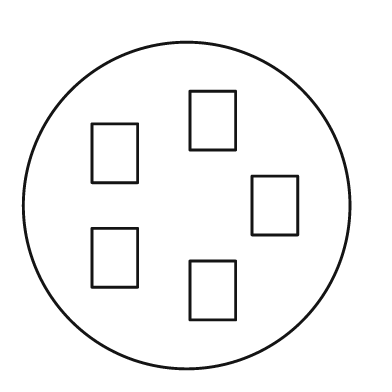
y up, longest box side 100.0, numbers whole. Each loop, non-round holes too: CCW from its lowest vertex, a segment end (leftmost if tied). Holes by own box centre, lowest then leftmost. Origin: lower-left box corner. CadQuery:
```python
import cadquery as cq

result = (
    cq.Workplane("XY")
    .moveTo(50.0, 50.0)
    .circle(50.0)
    .moveTo(51.0, 15.0)
    .lineTo(65.0, 15.0)
    .lineTo(65.0, 33.0)
    .lineTo(51.0, 33.0)
    .close()
    .moveTo(21.0, 25.0)
    .lineTo(35.0, 25.0)
    .lineTo(35.0, 43.0)
    .lineTo(21.0, 43.0)
    .close()
    .moveTo(70.0, 41.0)
    .lineTo(84.0, 41.0)
    .lineTo(84.0, 59.0)
    .lineTo(70.0, 59.0)
    .close()
    .moveTo(21.0, 57.0)
    .lineTo(35.0, 57.0)
    .lineTo(35.0, 75.0)
    .lineTo(21.0, 75.0)
    .close()
    .moveTo(51.0, 67.0)
    .lineTo(65.0, 67.0)
    .lineTo(65.0, 85.0)
    .lineTo(51.0, 85.0)
    .close()
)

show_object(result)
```